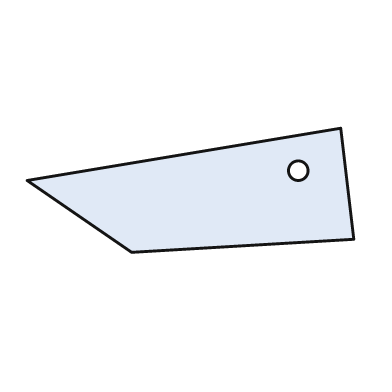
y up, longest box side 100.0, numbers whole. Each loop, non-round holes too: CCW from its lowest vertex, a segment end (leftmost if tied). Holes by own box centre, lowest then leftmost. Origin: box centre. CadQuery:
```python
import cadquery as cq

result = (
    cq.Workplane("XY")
    .moveTo(-18.0, -19.0)
    .lineTo(50.0, -15.0)
    .lineTo(46.0, 19.0)
    .lineTo(-50.0, 3.0)
    .close()
    .moveTo(33.0, 6.0)
    .circle(3.0)
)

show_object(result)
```